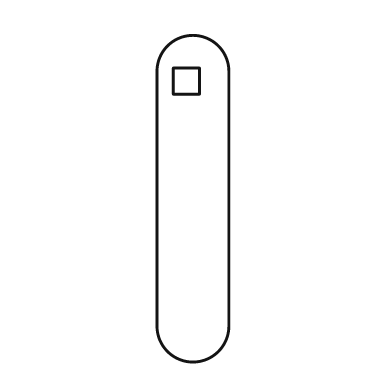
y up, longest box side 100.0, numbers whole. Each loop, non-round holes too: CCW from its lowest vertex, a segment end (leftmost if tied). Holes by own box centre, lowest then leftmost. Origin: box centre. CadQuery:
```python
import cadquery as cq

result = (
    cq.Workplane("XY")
    .moveTo(-11.0, -39.0)
    .threePointArc((0.0, -50.0), (11.0, -39.0))
    .lineTo(11.0, 39.0)
    .threePointArc((0.0, 50.0), (-11.0, 39.0))
    .close()
    .moveTo(-6.0, 32.0)
    .lineTo(2.0, 32.0)
    .lineTo(2.0, 40.0)
    .lineTo(-6.0, 40.0)
    .close()
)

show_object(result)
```